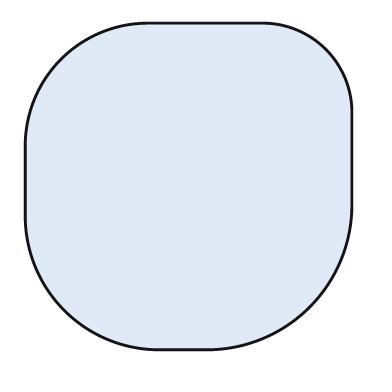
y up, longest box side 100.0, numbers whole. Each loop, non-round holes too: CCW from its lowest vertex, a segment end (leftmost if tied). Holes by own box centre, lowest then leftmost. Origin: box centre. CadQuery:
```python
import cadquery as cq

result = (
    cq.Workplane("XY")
    .moveTo(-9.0, -50.0)
    .lineTo(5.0, -50.0)
    .threePointArc((37.0, -37.0), (50.0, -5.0))
    .lineTo(50.0, 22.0)
    .threePointArc((42.0, 42.0), (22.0, 50.0))
    .lineTo(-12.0, 50.0)
    .threePointArc((-39.0, 39.0), (-50.0, 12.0))
    .lineTo(-50.0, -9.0)
    .threePointArc((-38.0, -38.0), (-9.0, -50.0))
    .close()
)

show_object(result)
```